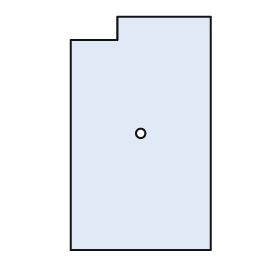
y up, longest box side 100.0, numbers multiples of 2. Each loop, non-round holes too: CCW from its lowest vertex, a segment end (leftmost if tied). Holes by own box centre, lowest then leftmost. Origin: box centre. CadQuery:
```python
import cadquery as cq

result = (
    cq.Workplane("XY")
    .moveTo(-30.0, -50.0)
    .lineTo(30.0, -50.0)
    .lineTo(30.0, 50.0)
    .lineTo(-10.0, 50.0)
    .lineTo(-10.0, 40.0)
    .lineTo(-30.0, 40.0)
    .close()
    .moveTo(0.0, 0.0)
    .circle(2.0)
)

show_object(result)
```